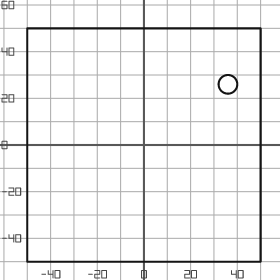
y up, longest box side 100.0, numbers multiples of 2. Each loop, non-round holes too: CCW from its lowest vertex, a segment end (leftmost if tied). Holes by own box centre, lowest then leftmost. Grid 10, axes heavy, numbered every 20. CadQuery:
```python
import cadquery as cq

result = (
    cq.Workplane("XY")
    .moveTo(-50.0, -50.0)
    .lineTo(50.0, -50.0)
    .lineTo(50.0, 50.0)
    .lineTo(-50.0, 50.0)
    .close()
    .moveTo(36.0, 26.0)
    .circle(4.0)
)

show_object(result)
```